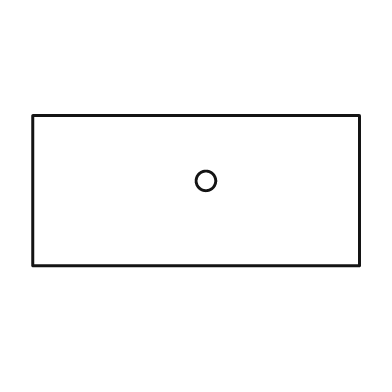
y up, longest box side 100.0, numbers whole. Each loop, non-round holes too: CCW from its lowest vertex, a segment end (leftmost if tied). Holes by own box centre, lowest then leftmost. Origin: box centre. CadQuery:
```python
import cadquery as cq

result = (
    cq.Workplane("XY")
    .moveTo(-50.0, -23.0)
    .lineTo(50.0, -23.0)
    .lineTo(50.0, 23.0)
    .lineTo(-50.0, 23.0)
    .close()
    .moveTo(3.0, 3.0)
    .circle(3.0)
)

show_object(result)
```